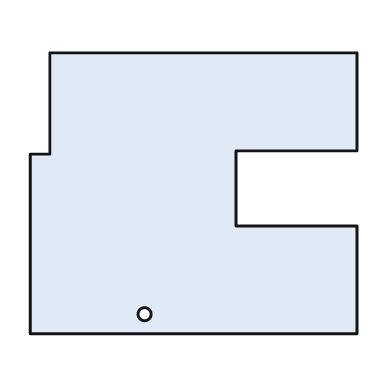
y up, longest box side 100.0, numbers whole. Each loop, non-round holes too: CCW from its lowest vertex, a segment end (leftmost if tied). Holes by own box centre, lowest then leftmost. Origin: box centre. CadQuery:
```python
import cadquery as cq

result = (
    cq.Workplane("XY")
    .moveTo(-50.0, -43.0)
    .lineTo(50.0, -43.0)
    .lineTo(50.0, -10.0)
    .lineTo(13.0, -10.0)
    .lineTo(13.0, 13.0)
    .lineTo(50.0, 13.0)
    .lineTo(50.0, 43.0)
    .lineTo(-44.0, 43.0)
    .lineTo(-44.0, 12.0)
    .lineTo(-50.0, 12.0)
    .close()
    .moveTo(-15.0, -37.0)
    .circle(2.0)
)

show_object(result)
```